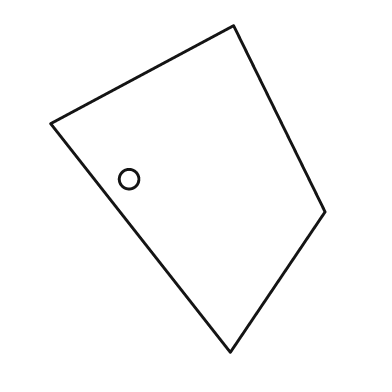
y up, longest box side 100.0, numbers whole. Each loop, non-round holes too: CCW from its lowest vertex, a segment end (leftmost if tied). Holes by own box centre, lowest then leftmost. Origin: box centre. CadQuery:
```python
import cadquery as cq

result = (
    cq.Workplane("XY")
    .moveTo(13.0, -50.0)
    .lineTo(42.0, -7.0)
    .lineTo(14.0, 50.0)
    .lineTo(-42.0, 20.0)
    .close()
    .moveTo(-18.0, 3.0)
    .circle(3.0)
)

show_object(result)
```